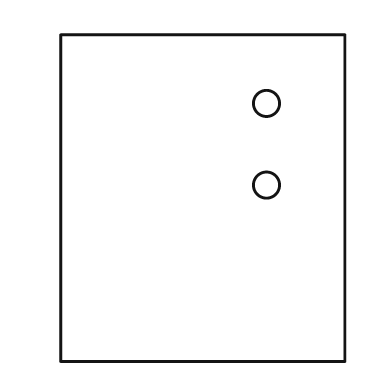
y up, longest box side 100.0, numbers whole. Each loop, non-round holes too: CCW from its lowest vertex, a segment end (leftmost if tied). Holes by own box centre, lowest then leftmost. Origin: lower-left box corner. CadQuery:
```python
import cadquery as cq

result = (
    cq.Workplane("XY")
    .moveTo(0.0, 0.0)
    .lineTo(87.0, 0.0)
    .lineTo(87.0, 100.0)
    .lineTo(0.0, 100.0)
    .close()
    .moveTo(63.0, 54.0)
    .circle(4.0)
    .moveTo(63.0, 79.0)
    .circle(4.0)
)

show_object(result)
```